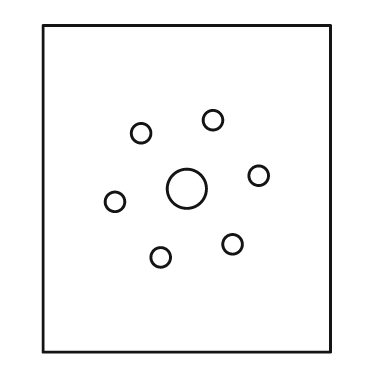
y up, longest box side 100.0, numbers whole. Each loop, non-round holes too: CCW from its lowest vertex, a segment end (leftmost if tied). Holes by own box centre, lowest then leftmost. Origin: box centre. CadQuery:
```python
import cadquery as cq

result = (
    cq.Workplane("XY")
    .moveTo(-44.0, -50.0)
    .lineTo(44.0, -50.0)
    .lineTo(44.0, 50.0)
    .lineTo(-44.0, 50.0)
    .close()
    .moveTo(-8.0, -21.0)
    .circle(3.0)
    .moveTo(14.0, -17.0)
    .circle(3.0)
    .moveTo(-22.0, -4.0)
    .circle(3.0)
    .moveTo(0.0, 0.0)
    .circle(6.0)
    .moveTo(22.0, 4.0)
    .circle(3.0)
    .moveTo(-14.0, 17.0)
    .circle(3.0)
    .moveTo(8.0, 21.0)
    .circle(3.0)
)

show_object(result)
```